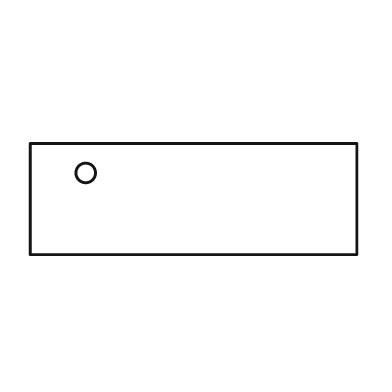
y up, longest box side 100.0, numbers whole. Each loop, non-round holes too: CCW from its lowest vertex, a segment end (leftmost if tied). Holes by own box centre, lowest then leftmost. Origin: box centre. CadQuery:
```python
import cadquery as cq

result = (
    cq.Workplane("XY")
    .moveTo(-50.0, -17.0)
    .lineTo(50.0, -17.0)
    .lineTo(50.0, 17.0)
    .lineTo(-50.0, 17.0)
    .close()
    .moveTo(-33.0, 8.0)
    .circle(3.0)
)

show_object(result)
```